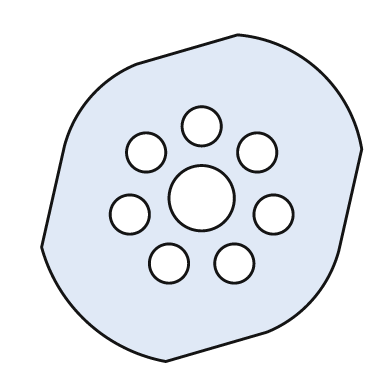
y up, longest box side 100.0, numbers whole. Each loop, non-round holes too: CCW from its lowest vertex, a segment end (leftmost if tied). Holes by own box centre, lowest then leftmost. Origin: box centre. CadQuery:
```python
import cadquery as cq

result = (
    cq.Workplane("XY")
    .moveTo(-11.0, -50.0)
    .lineTo(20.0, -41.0)
    .threePointArc((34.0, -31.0), (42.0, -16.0))
    .lineTo(49.0, 15.0)
    .threePointArc((36.0, 39.0), (11.0, 50.0))
    .lineTo(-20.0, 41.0)
    .threePointArc((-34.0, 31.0), (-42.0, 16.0))
    .lineTo(-49.0, -15.0)
    .threePointArc((-35.0, -38.0), (-11.0, -50.0))
    .close()
    .moveTo(-10.0, -20.0)
    .circle(6.0)
    .moveTo(10.0, -20.0)
    .circle(6.0)
    .moveTo(-22.0, -5.0)
    .circle(6.0)
    .moveTo(22.0, -5.0)
    .circle(6.0)
    .moveTo(0.0, 0.0)
    .circle(10.0)
    .moveTo(-17.0, 14.0)
    .circle(6.0)
    .moveTo(17.0, 14.0)
    .circle(6.0)
    .moveTo(0.0, 22.0)
    .circle(6.0)
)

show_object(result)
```